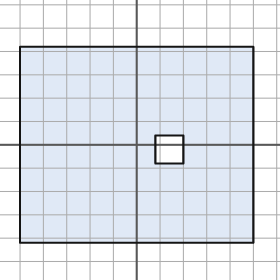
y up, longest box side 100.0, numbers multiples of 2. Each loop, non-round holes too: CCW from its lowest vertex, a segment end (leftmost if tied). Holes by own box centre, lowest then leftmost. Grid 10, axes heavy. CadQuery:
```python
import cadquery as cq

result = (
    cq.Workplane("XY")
    .moveTo(-50.0, -42.0)
    .lineTo(50.0, -42.0)
    .lineTo(50.0, 42.0)
    .lineTo(-50.0, 42.0)
    .close()
    .moveTo(8.0, -8.0)
    .lineTo(20.0, -8.0)
    .lineTo(20.0, 4.0)
    .lineTo(8.0, 4.0)
    .close()
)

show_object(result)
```